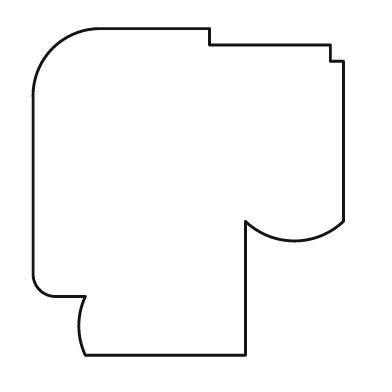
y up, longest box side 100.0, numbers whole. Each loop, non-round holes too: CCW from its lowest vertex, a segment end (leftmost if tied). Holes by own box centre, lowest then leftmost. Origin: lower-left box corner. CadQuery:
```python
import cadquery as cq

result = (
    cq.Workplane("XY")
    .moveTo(16.0, 0.0)
    .lineTo(65.0, 0.0)
    .lineTo(65.0, 41.0)
    .threePointArc((80.0, 35.0), (95.0, 41.0))
    .lineTo(95.0, 90.0)
    .lineTo(91.0, 90.0)
    .lineTo(91.0, 95.0)
    .lineTo(54.0, 95.0)
    .lineTo(54.0, 100.0)
    .lineTo(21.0, 100.0)
    .threePointArc((6.0, 94.0), (0.0, 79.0))
    .lineTo(0.0, 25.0)
    .threePointArc((2.0, 20.0), (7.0, 18.0))
    .lineTo(16.0, 18.0)
    .threePointArc((14.0, 9.0), (16.0, 0.0))
    .close()
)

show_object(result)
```